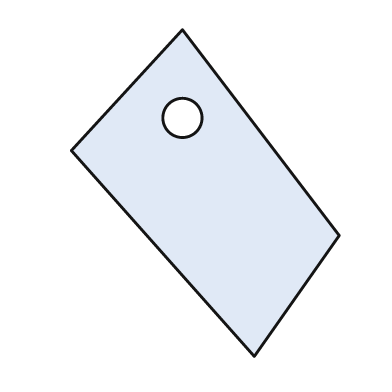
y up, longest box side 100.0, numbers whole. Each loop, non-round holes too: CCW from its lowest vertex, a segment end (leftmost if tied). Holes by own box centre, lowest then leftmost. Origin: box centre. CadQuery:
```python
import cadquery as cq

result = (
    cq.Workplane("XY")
    .moveTo(15.0, -50.0)
    .lineTo(41.0, -13.0)
    .lineTo(-7.0, 50.0)
    .lineTo(-41.0, 13.0)
    .close()
    .moveTo(-7.0, 23.0)
    .circle(6.0)
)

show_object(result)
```